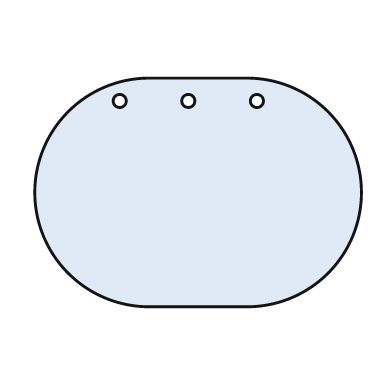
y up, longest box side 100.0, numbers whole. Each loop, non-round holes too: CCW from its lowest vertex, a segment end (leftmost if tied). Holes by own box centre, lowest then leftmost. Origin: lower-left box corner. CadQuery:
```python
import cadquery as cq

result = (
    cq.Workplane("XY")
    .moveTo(35.0, 0.0)
    .lineTo(65.0, 0.0)
    .threePointArc((100.0, 35.0), (65.0, 70.0))
    .lineTo(35.0, 70.0)
    .threePointArc((0.0, 35.0), (35.0, 0.0))
    .close()
    .moveTo(26.0, 63.0)
    .circle(2.0)
    .moveTo(47.0, 63.0)
    .circle(2.0)
    .moveTo(68.0, 63.0)
    .circle(2.0)
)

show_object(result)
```